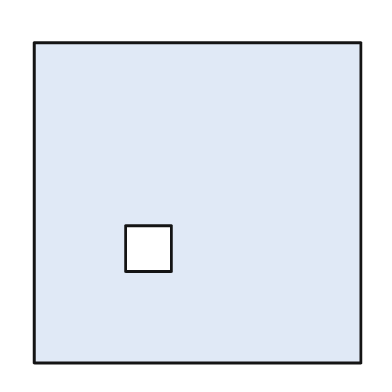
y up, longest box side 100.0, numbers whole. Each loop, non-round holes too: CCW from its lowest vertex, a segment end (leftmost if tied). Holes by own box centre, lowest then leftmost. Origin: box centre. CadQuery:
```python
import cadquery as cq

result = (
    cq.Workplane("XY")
    .moveTo(-50.0, -49.0)
    .lineTo(50.0, -49.0)
    .lineTo(50.0, 49.0)
    .lineTo(-50.0, 49.0)
    .close()
    .moveTo(-22.0, -21.0)
    .lineTo(-8.0, -21.0)
    .lineTo(-8.0, -7.0)
    .lineTo(-22.0, -7.0)
    .close()
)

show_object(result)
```